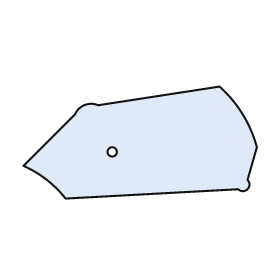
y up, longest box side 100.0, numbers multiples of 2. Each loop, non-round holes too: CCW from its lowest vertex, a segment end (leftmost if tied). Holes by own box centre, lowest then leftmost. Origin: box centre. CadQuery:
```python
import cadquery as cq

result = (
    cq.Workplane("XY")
    .moveTo(-32.0, -24.0)
    .lineTo(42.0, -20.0)
    .threePointArc((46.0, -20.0), (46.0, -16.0))
    .lineTo(50.0, -2.0)
    .threePointArc((44.0, 12.0), (34.0, 24.0))
    .lineTo(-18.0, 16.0)
    .threePointArc((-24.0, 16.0), (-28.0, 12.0))
    .lineTo(-50.0, -10.0)
    .threePointArc((-40.0, -16.0), (-32.0, -24.0))
    .close()
    .moveTo(-12.0, -4.0)
    .circle(2.0)
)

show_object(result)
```